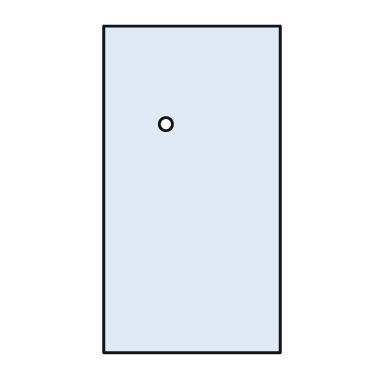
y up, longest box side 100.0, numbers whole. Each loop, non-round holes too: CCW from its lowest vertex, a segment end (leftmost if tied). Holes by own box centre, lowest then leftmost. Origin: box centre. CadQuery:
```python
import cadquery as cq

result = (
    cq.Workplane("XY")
    .moveTo(-27.0, -50.0)
    .lineTo(27.0, -50.0)
    .lineTo(27.0, 50.0)
    .lineTo(-27.0, 50.0)
    .close()
    .moveTo(-8.0, 20.0)
    .circle(2.0)
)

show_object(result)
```